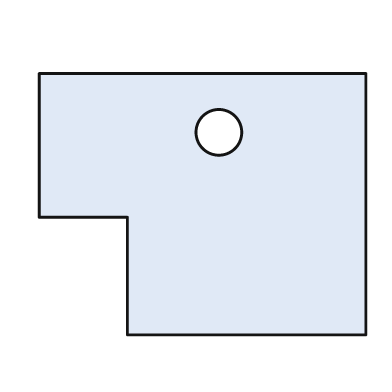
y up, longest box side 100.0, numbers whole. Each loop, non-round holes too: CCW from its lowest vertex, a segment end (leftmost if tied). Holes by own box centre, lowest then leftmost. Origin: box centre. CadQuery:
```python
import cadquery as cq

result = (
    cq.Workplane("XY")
    .moveTo(-23.0, -40.0)
    .lineTo(50.0, -40.0)
    .lineTo(50.0, 40.0)
    .lineTo(-50.0, 40.0)
    .lineTo(-50.0, -4.0)
    .lineTo(-23.0, -4.0)
    .close()
    .moveTo(5.0, 22.0)
    .circle(7.0)
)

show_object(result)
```